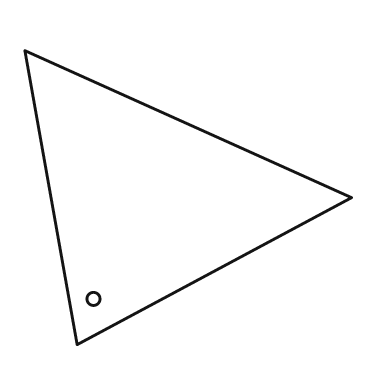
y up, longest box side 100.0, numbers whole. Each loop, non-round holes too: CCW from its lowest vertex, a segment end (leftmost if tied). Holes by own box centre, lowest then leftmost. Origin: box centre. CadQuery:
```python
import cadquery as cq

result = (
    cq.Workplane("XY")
    .moveTo(-34.0, -45.0)
    .lineTo(50.0, 0.0)
    .lineTo(-50.0, 45.0)
    .close()
    .moveTo(-29.0, -31.0)
    .circle(2.0)
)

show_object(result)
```